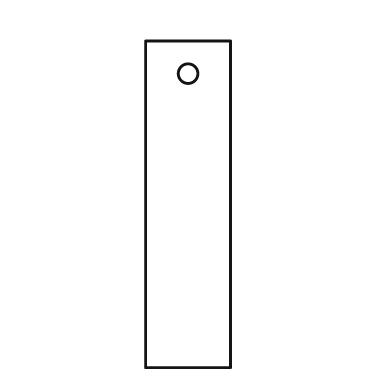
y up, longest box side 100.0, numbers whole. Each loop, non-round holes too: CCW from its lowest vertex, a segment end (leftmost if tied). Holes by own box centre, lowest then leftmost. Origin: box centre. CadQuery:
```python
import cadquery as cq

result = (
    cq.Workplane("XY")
    .moveTo(-13.0, -50.0)
    .lineTo(13.0, -50.0)
    .lineTo(13.0, 50.0)
    .lineTo(-13.0, 50.0)
    .close()
    .moveTo(0.0, 40.0)
    .circle(3.0)
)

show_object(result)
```